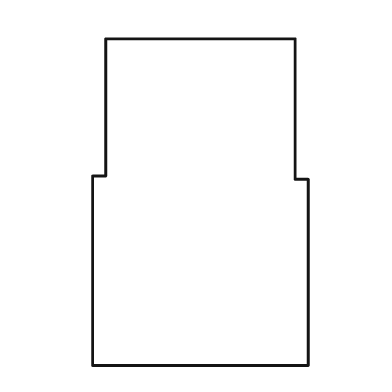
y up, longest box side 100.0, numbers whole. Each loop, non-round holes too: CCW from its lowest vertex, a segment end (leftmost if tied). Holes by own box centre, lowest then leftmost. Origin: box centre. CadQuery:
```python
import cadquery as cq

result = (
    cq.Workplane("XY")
    .moveTo(-33.0, -50.0)
    .lineTo(33.0, -50.0)
    .lineTo(33.0, 7.0)
    .lineTo(29.0, 7.0)
    .lineTo(29.0, 50.0)
    .lineTo(-29.0, 50.0)
    .lineTo(-29.0, 8.0)
    .lineTo(-33.0, 8.0)
    .close()
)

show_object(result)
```